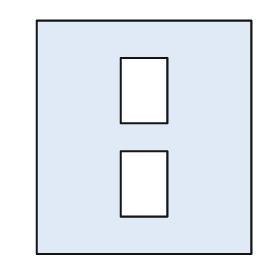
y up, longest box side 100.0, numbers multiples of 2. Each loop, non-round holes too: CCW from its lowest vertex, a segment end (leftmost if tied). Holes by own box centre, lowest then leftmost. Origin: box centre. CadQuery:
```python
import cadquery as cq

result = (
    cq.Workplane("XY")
    .moveTo(-46.0, -50.0)
    .lineTo(46.0, -50.0)
    .lineTo(46.0, 50.0)
    .lineTo(-46.0, 50.0)
    .close()
    .moveTo(-10.0, -34.0)
    .lineTo(10.0, -34.0)
    .lineTo(10.0, -6.0)
    .lineTo(-10.0, -6.0)
    .close()
    .moveTo(-10.0, 6.0)
    .lineTo(10.0, 6.0)
    .lineTo(10.0, 34.0)
    .lineTo(-10.0, 34.0)
    .close()
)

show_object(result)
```